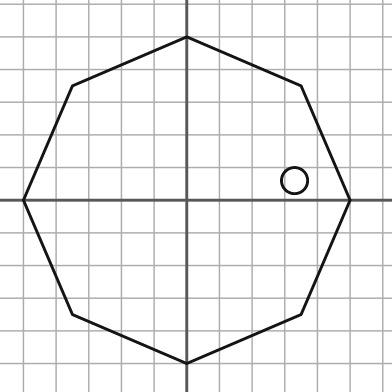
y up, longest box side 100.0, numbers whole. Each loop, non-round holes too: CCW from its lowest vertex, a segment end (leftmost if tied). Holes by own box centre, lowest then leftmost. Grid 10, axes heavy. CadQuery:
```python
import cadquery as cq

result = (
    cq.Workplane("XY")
    .moveTo(0.0, -50.0)
    .lineTo(35.0, -35.0)
    .lineTo(50.0, 0.0)
    .lineTo(35.0, 35.0)
    .lineTo(0.0, 50.0)
    .lineTo(-35.0, 35.0)
    .lineTo(-50.0, 0.0)
    .lineTo(-35.0, -35.0)
    .close()
    .moveTo(33.0, 6.0)
    .circle(4.0)
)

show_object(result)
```